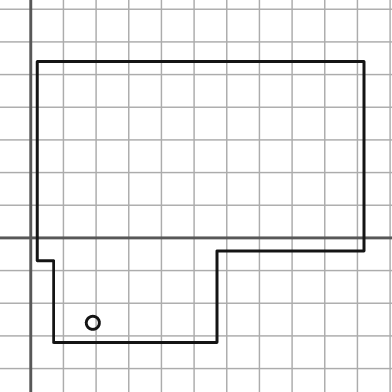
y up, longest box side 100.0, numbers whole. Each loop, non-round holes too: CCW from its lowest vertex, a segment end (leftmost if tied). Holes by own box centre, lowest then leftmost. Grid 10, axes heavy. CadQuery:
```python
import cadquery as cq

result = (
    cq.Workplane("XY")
    .moveTo(7.0, -32.0)
    .lineTo(57.0, -32.0)
    .lineTo(57.0, -4.0)
    .lineTo(102.0, -4.0)
    .lineTo(102.0, 54.0)
    .lineTo(2.0, 54.0)
    .lineTo(2.0, -7.0)
    .lineTo(7.0, -7.0)
    .close()
    .moveTo(19.0, -26.0)
    .circle(2.0)
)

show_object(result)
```